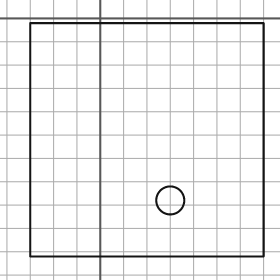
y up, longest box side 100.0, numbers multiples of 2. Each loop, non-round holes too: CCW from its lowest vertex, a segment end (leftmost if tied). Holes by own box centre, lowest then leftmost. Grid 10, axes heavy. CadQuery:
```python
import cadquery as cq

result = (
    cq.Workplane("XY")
    .moveTo(-30.0, -102.0)
    .lineTo(70.0, -102.0)
    .lineTo(70.0, -2.0)
    .lineTo(-30.0, -2.0)
    .close()
    .moveTo(30.0, -78.0)
    .circle(6.0)
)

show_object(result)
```